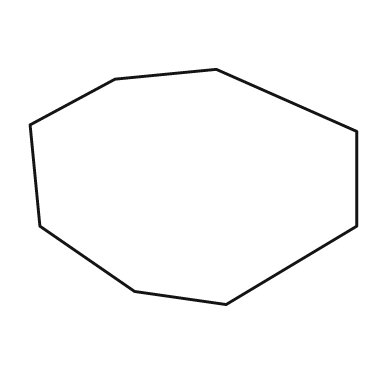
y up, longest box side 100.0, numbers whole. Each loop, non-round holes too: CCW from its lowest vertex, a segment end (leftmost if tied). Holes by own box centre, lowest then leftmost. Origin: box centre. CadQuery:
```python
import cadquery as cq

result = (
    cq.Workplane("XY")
    .moveTo(10.0, -36.0)
    .lineTo(50.0, -12.0)
    .lineTo(50.0, 17.0)
    .lineTo(7.0, 36.0)
    .lineTo(-24.0, 33.0)
    .lineTo(-50.0, 19.0)
    .lineTo(-47.0, -12.0)
    .lineTo(-18.0, -32.0)
    .close()
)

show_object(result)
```